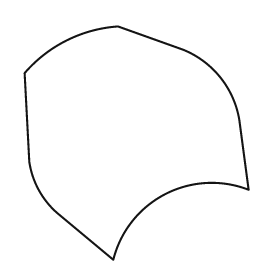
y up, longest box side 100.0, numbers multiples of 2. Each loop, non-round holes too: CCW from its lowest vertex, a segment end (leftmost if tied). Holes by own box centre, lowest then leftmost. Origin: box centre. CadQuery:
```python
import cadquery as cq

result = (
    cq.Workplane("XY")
    .moveTo(-10.0, -50.0)
    .threePointArc((12.0, -22.0), (48.0, -20.0))
    .lineTo(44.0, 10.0)
    .threePointArc((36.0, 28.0), (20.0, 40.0))
    .lineTo(-8.0, 50.0)
    .threePointArc((-30.0, 44.0), (-48.0, 30.0))
    .lineTo(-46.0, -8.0)
    .threePointArc((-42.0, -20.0), (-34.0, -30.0))
    .close()
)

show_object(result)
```